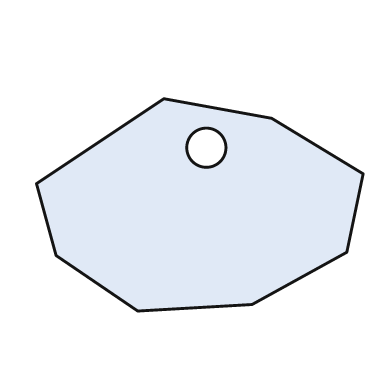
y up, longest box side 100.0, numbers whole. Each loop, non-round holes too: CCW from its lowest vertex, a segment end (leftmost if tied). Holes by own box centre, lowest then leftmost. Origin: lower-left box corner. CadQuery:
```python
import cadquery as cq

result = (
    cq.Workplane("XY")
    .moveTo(31.0, 0.0)
    .lineTo(66.0, 2.0)
    .lineTo(95.0, 18.0)
    .lineTo(100.0, 42.0)
    .lineTo(72.0, 59.0)
    .lineTo(39.0, 65.0)
    .lineTo(0.0, 39.0)
    .lineTo(6.0, 17.0)
    .close()
    .moveTo(52.0, 50.0)
    .circle(6.0)
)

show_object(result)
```